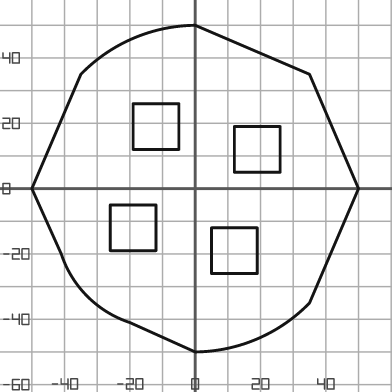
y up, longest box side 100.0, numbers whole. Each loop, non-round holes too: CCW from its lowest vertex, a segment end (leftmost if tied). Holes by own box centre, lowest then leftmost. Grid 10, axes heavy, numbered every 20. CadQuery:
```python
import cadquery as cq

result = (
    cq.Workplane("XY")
    .moveTo(0.0, -50.0)
    .threePointArc((19.0, -46.0), (35.0, -35.0))
    .lineTo(50.0, 0.0)
    .lineTo(35.0, 35.0)
    .lineTo(0.0, 50.0)
    .threePointArc((-19.0, 46.0), (-35.0, 35.0))
    .lineTo(-50.0, 0.0)
    .lineTo(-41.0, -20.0)
    .threePointArc((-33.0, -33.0), (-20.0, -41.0))
    .close()
    .moveTo(5.0, -26.0)
    .lineTo(19.0, -26.0)
    .lineTo(19.0, -12.0)
    .lineTo(5.0, -12.0)
    .close()
    .moveTo(-26.0, -19.0)
    .lineTo(-12.0, -19.0)
    .lineTo(-12.0, -5.0)
    .lineTo(-26.0, -5.0)
    .close()
    .moveTo(12.0, 5.0)
    .lineTo(26.0, 5.0)
    .lineTo(26.0, 19.0)
    .lineTo(12.0, 19.0)
    .close()
    .moveTo(-19.0, 12.0)
    .lineTo(-5.0, 12.0)
    .lineTo(-5.0, 26.0)
    .lineTo(-19.0, 26.0)
    .close()
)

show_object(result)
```